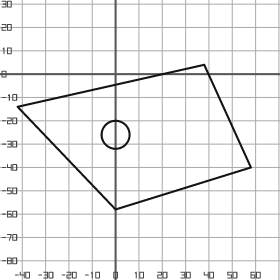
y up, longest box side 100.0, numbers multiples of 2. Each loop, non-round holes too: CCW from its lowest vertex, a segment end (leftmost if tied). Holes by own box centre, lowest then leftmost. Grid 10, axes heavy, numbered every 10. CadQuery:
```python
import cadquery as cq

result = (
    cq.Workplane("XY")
    .moveTo(0.0, -58.0)
    .lineTo(58.0, -40.0)
    .lineTo(38.0, 4.0)
    .lineTo(-42.0, -14.0)
    .close()
    .moveTo(0.0, -26.0)
    .circle(6.0)
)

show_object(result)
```